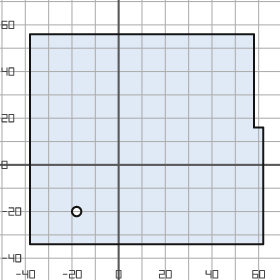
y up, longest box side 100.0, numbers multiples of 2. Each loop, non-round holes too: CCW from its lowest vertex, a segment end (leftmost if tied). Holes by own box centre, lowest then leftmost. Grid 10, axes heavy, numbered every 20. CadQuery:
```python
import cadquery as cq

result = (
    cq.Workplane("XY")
    .moveTo(-38.0, -34.0)
    .lineTo(62.0, -34.0)
    .lineTo(62.0, 16.0)
    .lineTo(58.0, 16.0)
    .lineTo(58.0, 56.0)
    .lineTo(-38.0, 56.0)
    .close()
    .moveTo(-18.0, -20.0)
    .circle(2.0)
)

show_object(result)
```